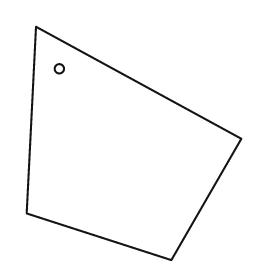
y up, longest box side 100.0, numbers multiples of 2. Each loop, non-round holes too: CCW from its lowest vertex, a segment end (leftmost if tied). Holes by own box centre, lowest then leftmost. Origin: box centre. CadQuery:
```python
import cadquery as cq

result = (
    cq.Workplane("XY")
    .moveTo(16.0, -50.0)
    .lineTo(46.0, 2.0)
    .lineTo(-42.0, 50.0)
    .lineTo(-46.0, -30.0)
    .close()
    .moveTo(-32.0, 32.0)
    .circle(2.0)
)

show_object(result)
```